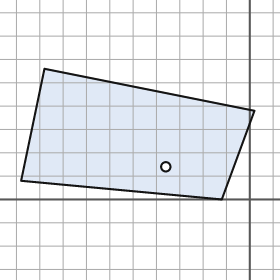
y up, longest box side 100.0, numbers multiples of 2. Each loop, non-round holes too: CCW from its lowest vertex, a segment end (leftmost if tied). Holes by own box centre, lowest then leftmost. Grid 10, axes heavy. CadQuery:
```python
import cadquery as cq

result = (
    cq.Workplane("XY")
    .moveTo(-12.0, 0.0)
    .lineTo(2.0, 38.0)
    .lineTo(-88.0, 56.0)
    .lineTo(-98.0, 8.0)
    .close()
    .moveTo(-36.0, 14.0)
    .circle(2.0)
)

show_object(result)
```